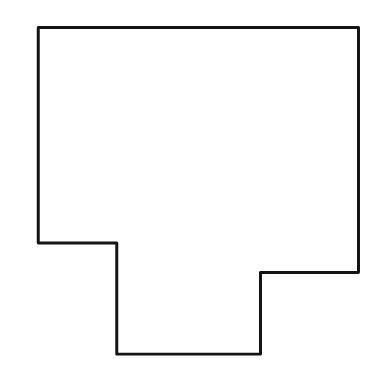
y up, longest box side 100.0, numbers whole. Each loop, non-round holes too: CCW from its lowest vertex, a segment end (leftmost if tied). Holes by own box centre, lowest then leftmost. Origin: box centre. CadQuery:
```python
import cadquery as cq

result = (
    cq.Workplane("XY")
    .moveTo(-25.0, -50.0)
    .lineTo(19.0, -50.0)
    .lineTo(19.0, -25.0)
    .lineTo(49.0, -25.0)
    .lineTo(49.0, 50.0)
    .lineTo(-49.0, 50.0)
    .lineTo(-49.0, -16.0)
    .lineTo(-25.0, -16.0)
    .close()
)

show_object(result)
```